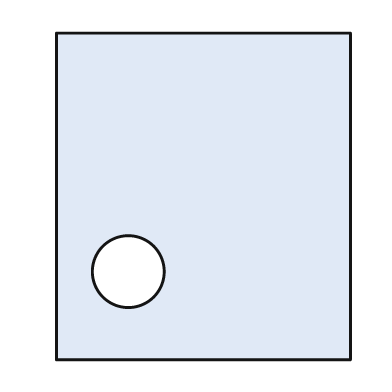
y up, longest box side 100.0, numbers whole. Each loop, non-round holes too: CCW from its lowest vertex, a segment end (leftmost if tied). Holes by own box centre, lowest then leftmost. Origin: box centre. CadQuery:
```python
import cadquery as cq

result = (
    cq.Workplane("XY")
    .moveTo(-45.0, -50.0)
    .lineTo(45.0, -50.0)
    .lineTo(45.0, 50.0)
    .lineTo(-45.0, 50.0)
    .close()
    .moveTo(-23.0, -23.0)
    .circle(11.0)
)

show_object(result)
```